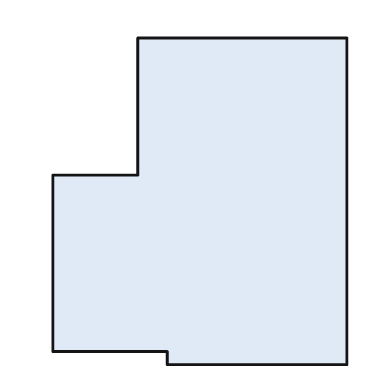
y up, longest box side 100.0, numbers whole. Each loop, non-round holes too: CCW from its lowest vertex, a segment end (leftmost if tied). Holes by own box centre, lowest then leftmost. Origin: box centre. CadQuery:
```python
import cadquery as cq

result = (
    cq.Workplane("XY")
    .moveTo(-10.0, -50.0)
    .lineTo(45.0, -50.0)
    .lineTo(45.0, 50.0)
    .lineTo(-19.0, 50.0)
    .lineTo(-19.0, 8.0)
    .lineTo(-45.0, 8.0)
    .lineTo(-45.0, -46.0)
    .lineTo(-10.0, -46.0)
    .close()
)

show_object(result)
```